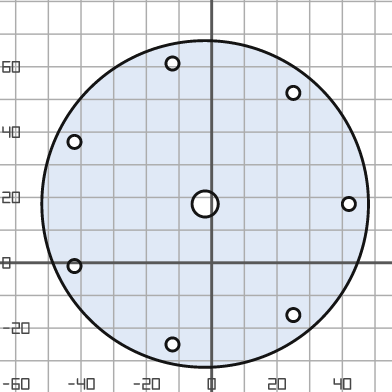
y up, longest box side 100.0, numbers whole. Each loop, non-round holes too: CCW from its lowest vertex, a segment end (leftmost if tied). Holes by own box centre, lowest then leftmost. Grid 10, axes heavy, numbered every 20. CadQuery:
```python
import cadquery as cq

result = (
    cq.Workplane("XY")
    .moveTo(-2.0, 18.0)
    .circle(50.0)
    .moveTo(-12.0, -25.0)
    .circle(2.0)
    .moveTo(25.0, -16.0)
    .circle(2.0)
    .moveTo(-42.0, -1.0)
    .circle(2.0)
    .moveTo(-2.0, 18.0)
    .circle(4.0)
    .moveTo(42.0, 18.0)
    .circle(2.0)
    .moveTo(-42.0, 37.0)
    .circle(2.0)
    .moveTo(25.0, 52.0)
    .circle(2.0)
    .moveTo(-12.0, 61.0)
    .circle(2.0)
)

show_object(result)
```